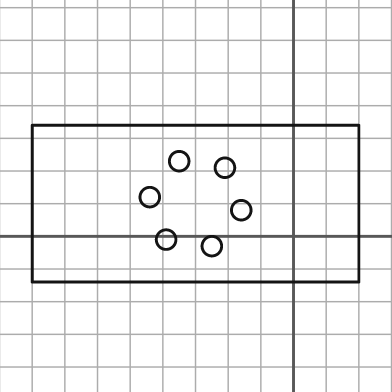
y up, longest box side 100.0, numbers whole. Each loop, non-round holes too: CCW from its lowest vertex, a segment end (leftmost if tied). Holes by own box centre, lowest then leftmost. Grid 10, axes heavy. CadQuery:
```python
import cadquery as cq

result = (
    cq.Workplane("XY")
    .moveTo(-80.0, -14.0)
    .lineTo(20.0, -14.0)
    .lineTo(20.0, 34.0)
    .lineTo(-80.0, 34.0)
    .close()
    .moveTo(-25.0, -3.0)
    .circle(3.0)
    .moveTo(-39.0, -1.0)
    .circle(3.0)
    .moveTo(-16.0, 8.0)
    .circle(3.0)
    .moveTo(-44.0, 12.0)
    .circle(3.0)
    .moveTo(-21.0, 21.0)
    .circle(3.0)
    .moveTo(-35.0, 23.0)
    .circle(3.0)
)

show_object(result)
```